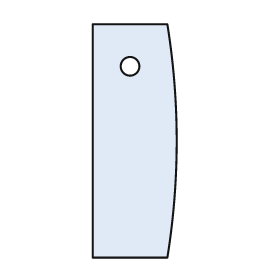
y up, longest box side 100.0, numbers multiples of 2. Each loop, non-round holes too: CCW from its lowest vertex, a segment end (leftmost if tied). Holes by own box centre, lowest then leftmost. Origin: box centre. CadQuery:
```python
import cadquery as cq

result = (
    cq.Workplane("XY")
    .moveTo(-18.0, -50.0)
    .lineTo(14.0, -50.0)
    .threePointArc((18.0, 0.0), (14.0, 50.0))
    .lineTo(-18.0, 50.0)
    .close()
    .moveTo(-2.0, 32.0)
    .circle(4.0)
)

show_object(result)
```